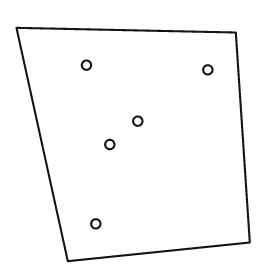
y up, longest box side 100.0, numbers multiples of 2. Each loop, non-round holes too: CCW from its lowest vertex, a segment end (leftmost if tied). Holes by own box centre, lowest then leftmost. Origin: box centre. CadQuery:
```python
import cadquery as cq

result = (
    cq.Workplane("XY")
    .moveTo(-28.0, -50.0)
    .lineTo(50.0, -42.0)
    .lineTo(44.0, 48.0)
    .lineTo(-50.0, 50.0)
    .close()
    .moveTo(-16.0, -34.0)
    .circle(2.0)
    .moveTo(-10.0, 0.0)
    .circle(2.0)
    .moveTo(2.0, 10.0)
    .circle(2.0)
    .moveTo(32.0, 32.0)
    .circle(2.0)
    .moveTo(-20.0, 34.0)
    .circle(2.0)
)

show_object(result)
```